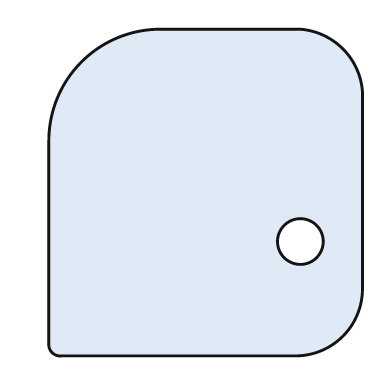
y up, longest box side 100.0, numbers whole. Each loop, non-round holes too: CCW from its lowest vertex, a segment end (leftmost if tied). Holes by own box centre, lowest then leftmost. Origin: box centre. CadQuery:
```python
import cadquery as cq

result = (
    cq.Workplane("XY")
    .moveTo(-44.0, -50.0)
    .lineTo(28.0, -50.0)
    .threePointArc((42.0, -44.0), (48.0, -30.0))
    .lineTo(48.0, 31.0)
    .threePointArc((42.0, 44.0), (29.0, 50.0))
    .lineTo(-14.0, 50.0)
    .threePointArc((-38.0, 40.0), (-48.0, 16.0))
    .lineTo(-48.0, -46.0)
    .threePointArc((-47.0, -49.0), (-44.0, -50.0))
    .close()
    .moveTo(29.0, -15.0)
    .circle(7.0)
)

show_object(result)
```